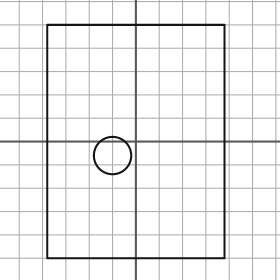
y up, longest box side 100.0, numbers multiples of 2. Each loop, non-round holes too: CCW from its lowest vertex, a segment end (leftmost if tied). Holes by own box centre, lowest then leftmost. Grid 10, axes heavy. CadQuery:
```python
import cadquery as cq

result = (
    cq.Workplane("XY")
    .moveTo(-38.0, -50.0)
    .lineTo(38.0, -50.0)
    .lineTo(38.0, 50.0)
    .lineTo(-38.0, 50.0)
    .close()
    .moveTo(-10.0, -6.0)
    .circle(8.0)
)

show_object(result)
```